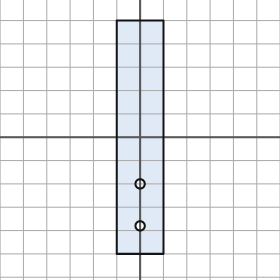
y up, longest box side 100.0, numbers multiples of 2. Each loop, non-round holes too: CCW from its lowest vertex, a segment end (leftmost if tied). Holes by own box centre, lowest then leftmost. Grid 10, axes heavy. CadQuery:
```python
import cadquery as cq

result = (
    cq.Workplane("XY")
    .moveTo(-10.0, -50.0)
    .lineTo(10.0, -50.0)
    .lineTo(10.0, 50.0)
    .lineTo(-10.0, 50.0)
    .close()
    .moveTo(0.0, -38.0)
    .circle(2.0)
    .moveTo(0.0, -20.0)
    .circle(2.0)
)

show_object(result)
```